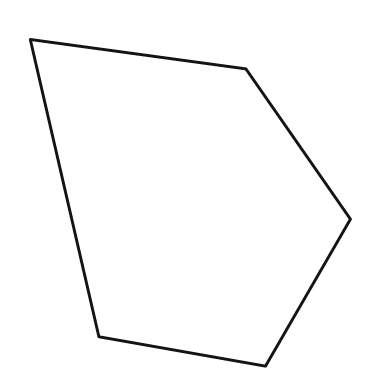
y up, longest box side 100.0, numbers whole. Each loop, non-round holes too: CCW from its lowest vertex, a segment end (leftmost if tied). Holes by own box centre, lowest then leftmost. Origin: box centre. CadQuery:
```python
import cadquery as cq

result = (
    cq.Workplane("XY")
    .moveTo(23.0, -50.0)
    .lineTo(49.0, -5.0)
    .lineTo(17.0, 41.0)
    .lineTo(-49.0, 50.0)
    .lineTo(-28.0, -41.0)
    .close()
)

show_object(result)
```